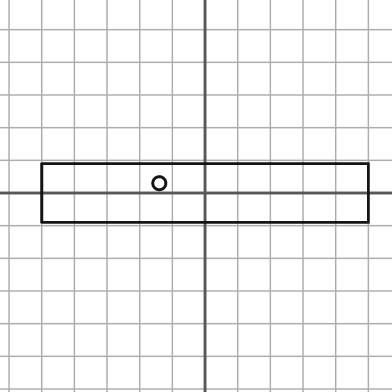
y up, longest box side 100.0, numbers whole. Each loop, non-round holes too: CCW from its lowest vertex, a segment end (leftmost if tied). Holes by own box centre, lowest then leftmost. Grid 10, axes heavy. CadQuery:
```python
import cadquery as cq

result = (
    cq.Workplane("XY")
    .moveTo(-50.0, -9.0)
    .lineTo(50.0, -9.0)
    .lineTo(50.0, 9.0)
    .lineTo(-50.0, 9.0)
    .close()
    .moveTo(-14.0, 3.0)
    .circle(2.0)
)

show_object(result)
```